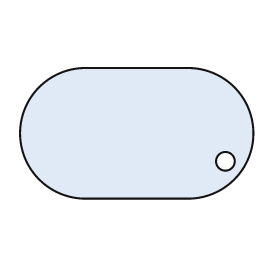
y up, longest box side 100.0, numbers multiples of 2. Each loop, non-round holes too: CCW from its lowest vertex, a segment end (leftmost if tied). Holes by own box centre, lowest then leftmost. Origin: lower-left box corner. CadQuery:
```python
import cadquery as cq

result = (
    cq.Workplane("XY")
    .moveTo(28.0, 0.0)
    .lineTo(72.0, 0.0)
    .threePointArc((100.0, 28.0), (72.0, 56.0))
    .lineTo(28.0, 56.0)
    .threePointArc((0.0, 28.0), (28.0, 0.0))
    .close()
    .moveTo(88.0, 16.0)
    .circle(4.0)
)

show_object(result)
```